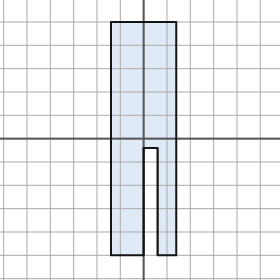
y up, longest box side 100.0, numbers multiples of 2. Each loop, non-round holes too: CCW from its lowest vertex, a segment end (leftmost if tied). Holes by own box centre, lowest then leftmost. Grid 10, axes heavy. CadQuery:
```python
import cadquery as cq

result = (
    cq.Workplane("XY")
    .moveTo(-14.0, -50.0)
    .lineTo(0.0, -50.0)
    .lineTo(0.0, -4.0)
    .lineTo(6.0, -4.0)
    .lineTo(6.0, -50.0)
    .lineTo(14.0, -50.0)
    .lineTo(14.0, 50.0)
    .lineTo(-14.0, 50.0)
    .close()
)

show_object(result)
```